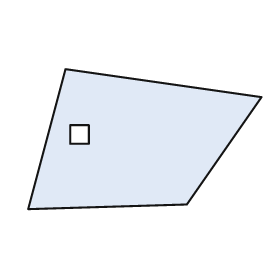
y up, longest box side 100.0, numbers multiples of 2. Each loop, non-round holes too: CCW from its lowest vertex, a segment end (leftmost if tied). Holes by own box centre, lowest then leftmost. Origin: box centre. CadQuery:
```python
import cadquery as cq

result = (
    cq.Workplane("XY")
    .moveTo(-50.0, -30.0)
    .lineTo(18.0, -28.0)
    .lineTo(50.0, 18.0)
    .lineTo(-34.0, 30.0)
    .close()
    .moveTo(-32.0, -2.0)
    .lineTo(-24.0, -2.0)
    .lineTo(-24.0, 6.0)
    .lineTo(-32.0, 6.0)
    .close()
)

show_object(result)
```